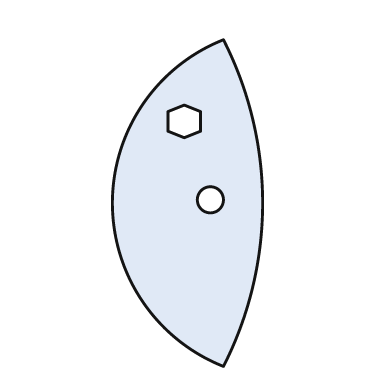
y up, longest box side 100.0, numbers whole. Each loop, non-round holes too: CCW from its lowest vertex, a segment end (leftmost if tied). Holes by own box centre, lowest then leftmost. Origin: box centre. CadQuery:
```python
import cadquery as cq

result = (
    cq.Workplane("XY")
    .moveTo(11.0, -50.0)
    .threePointArc((23.0, 0.0), (11.0, 50.0))
    .threePointArc((-23.0, 0.0), (11.0, -50.0))
    .close()
    .moveTo(7.0, 1.0)
    .circle(4.0)
    .moveTo(-1.0, 20.0)
    .lineTo(4.0, 22.0)
    .lineTo(4.0, 28.0)
    .lineTo(-1.0, 30.0)
    .lineTo(-6.0, 28.0)
    .lineTo(-6.0, 22.0)
    .close()
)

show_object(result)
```